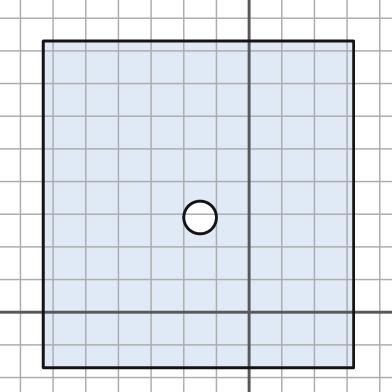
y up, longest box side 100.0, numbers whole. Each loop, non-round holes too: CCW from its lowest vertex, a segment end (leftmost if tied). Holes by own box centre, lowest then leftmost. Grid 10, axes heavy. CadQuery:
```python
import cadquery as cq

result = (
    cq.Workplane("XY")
    .moveTo(-63.0, -17.0)
    .lineTo(32.0, -17.0)
    .lineTo(32.0, 83.0)
    .lineTo(-63.0, 83.0)
    .close()
    .moveTo(-15.0, 29.0)
    .circle(5.0)
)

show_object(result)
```